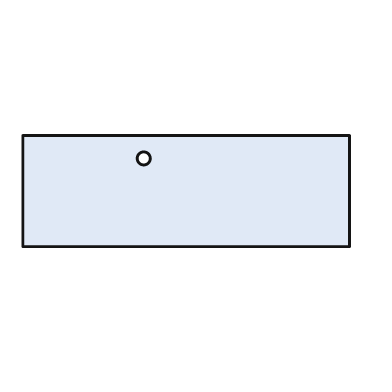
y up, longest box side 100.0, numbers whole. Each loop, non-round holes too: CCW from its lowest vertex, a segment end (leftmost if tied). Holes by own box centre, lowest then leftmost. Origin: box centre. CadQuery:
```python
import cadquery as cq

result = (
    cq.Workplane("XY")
    .moveTo(-50.0, -17.0)
    .lineTo(50.0, -17.0)
    .lineTo(50.0, 17.0)
    .lineTo(-50.0, 17.0)
    .close()
    .moveTo(-13.0, 10.0)
    .circle(2.0)
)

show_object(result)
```